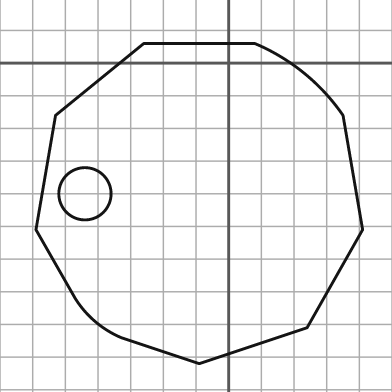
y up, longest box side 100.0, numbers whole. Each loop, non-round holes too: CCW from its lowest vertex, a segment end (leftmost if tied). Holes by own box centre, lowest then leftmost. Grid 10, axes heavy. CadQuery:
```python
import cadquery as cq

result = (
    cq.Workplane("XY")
    .moveTo(-9.0, -92.0)
    .lineTo(24.0, -81.0)
    .lineTo(41.0, -51.0)
    .lineTo(35.0, -16.0)
    .threePointArc((23.0, -3.0), (8.0, 6.0))
    .lineTo(-26.0, 6.0)
    .lineTo(-53.0, -16.0)
    .lineTo(-59.0, -51.0)
    .lineTo(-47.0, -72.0)
    .threePointArc((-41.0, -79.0), (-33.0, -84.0))
    .close()
    .moveTo(-44.0, -40.0)
    .circle(8.0)
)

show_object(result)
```